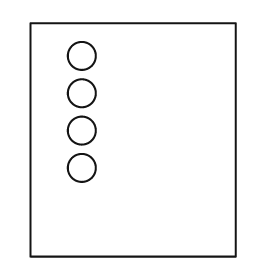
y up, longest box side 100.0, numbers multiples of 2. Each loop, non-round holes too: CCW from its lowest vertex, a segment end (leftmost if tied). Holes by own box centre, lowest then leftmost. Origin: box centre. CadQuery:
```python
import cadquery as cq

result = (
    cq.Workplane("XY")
    .moveTo(-44.0, -50.0)
    .lineTo(44.0, -50.0)
    .lineTo(44.0, 50.0)
    .lineTo(-44.0, 50.0)
    .close()
    .moveTo(-22.0, -12.0)
    .circle(6.0)
    .moveTo(-22.0, 4.0)
    .circle(6.0)
    .moveTo(-22.0, 20.0)
    .circle(6.0)
    .moveTo(-22.0, 36.0)
    .circle(6.0)
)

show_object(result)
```